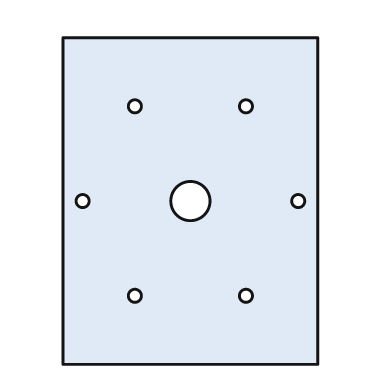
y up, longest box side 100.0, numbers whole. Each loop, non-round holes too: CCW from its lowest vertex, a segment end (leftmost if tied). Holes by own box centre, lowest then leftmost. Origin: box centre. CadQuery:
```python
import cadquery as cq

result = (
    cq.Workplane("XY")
    .moveTo(-39.0, -50.0)
    .lineTo(39.0, -50.0)
    .lineTo(39.0, 50.0)
    .lineTo(-39.0, 50.0)
    .close()
    .moveTo(-17.0, -29.0)
    .circle(2.0)
    .moveTo(17.0, -29.0)
    .circle(2.0)
    .moveTo(-33.0, 0.0)
    .circle(2.0)
    .moveTo(0.0, 0.0)
    .circle(6.0)
    .moveTo(33.0, 0.0)
    .circle(2.0)
    .moveTo(-17.0, 29.0)
    .circle(2.0)
    .moveTo(17.0, 29.0)
    .circle(2.0)
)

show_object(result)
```